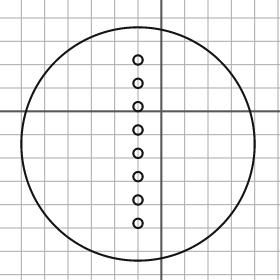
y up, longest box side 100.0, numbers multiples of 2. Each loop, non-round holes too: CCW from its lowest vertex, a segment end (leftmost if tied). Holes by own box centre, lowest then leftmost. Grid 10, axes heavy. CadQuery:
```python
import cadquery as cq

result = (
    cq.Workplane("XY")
    .moveTo(-10.0, -14.0)
    .circle(50.0)
    .moveTo(-10.0, -48.0)
    .circle(2.0)
    .moveTo(-10.0, -38.0)
    .circle(2.0)
    .moveTo(-10.0, -28.0)
    .circle(2.0)
    .moveTo(-10.0, -18.0)
    .circle(2.0)
    .moveTo(-10.0, -8.0)
    .circle(2.0)
    .moveTo(-10.0, 2.0)
    .circle(2.0)
    .moveTo(-10.0, 12.0)
    .circle(2.0)
    .moveTo(-10.0, 22.0)
    .circle(2.0)
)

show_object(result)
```